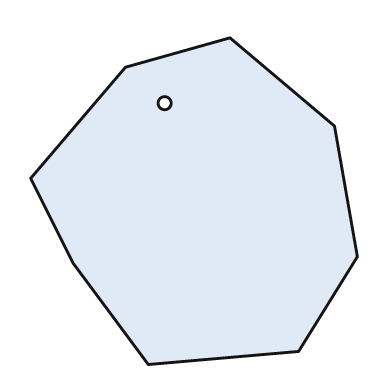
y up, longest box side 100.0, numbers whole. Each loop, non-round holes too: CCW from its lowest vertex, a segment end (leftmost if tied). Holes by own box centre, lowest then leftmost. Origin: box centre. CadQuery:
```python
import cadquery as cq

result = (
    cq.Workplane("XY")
    .moveTo(-14.0, -50.0)
    .lineTo(32.0, -46.0)
    .lineTo(50.0, -17.0)
    .lineTo(43.0, 23.0)
    .lineTo(11.0, 50.0)
    .lineTo(-21.0, 41.0)
    .lineTo(-50.0, 7.0)
    .lineTo(-37.0, -19.0)
    .close()
    .moveTo(-9.0, 30.0)
    .circle(2.0)
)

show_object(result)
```